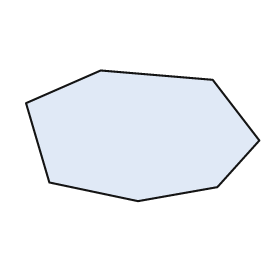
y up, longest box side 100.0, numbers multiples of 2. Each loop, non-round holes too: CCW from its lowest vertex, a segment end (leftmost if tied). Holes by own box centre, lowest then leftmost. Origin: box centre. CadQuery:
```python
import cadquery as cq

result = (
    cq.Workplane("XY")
    .moveTo(-2.0, -28.0)
    .lineTo(32.0, -22.0)
    .lineTo(50.0, -2.0)
    .lineTo(30.0, 24.0)
    .lineTo(-18.0, 28.0)
    .lineTo(-50.0, 14.0)
    .lineTo(-40.0, -20.0)
    .close()
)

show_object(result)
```